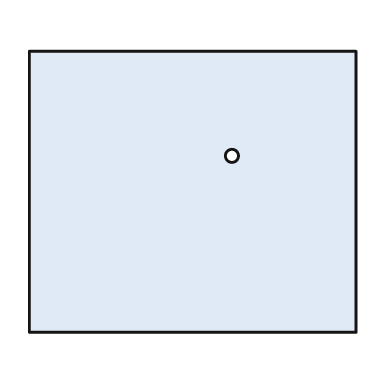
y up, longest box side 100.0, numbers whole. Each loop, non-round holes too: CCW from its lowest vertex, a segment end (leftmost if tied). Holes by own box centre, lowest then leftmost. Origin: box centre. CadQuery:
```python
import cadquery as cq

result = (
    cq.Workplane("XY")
    .moveTo(-50.0, -43.0)
    .lineTo(50.0, -43.0)
    .lineTo(50.0, 43.0)
    .lineTo(-50.0, 43.0)
    .close()
    .moveTo(12.0, 11.0)
    .circle(2.0)
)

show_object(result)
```